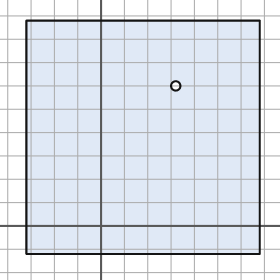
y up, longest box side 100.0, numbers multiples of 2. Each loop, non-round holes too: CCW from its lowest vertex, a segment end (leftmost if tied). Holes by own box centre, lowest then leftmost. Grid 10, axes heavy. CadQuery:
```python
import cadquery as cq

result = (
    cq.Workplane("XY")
    .moveTo(-32.0, -12.0)
    .lineTo(68.0, -12.0)
    .lineTo(68.0, 88.0)
    .lineTo(-32.0, 88.0)
    .close()
    .moveTo(32.0, 60.0)
    .circle(2.0)
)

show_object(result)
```